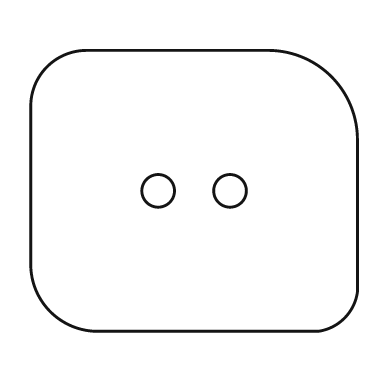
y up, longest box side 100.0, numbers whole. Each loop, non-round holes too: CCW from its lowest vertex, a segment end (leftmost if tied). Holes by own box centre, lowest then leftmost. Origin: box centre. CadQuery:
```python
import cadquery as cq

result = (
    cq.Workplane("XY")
    .moveTo(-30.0, -43.0)
    .lineTo(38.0, -43.0)
    .threePointArc((46.0, -39.0), (50.0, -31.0))
    .lineTo(50.0, 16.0)
    .threePointArc((42.0, 35.0), (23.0, 43.0))
    .lineTo(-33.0, 43.0)
    .threePointArc((-45.0, 38.0), (-50.0, 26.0))
    .lineTo(-50.0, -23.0)
    .threePointArc((-44.0, -37.0), (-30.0, -43.0))
    .close()
    .moveTo(-11.0, 0.0)
    .circle(5.0)
    .moveTo(11.0, 0.0)
    .circle(5.0)
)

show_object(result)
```